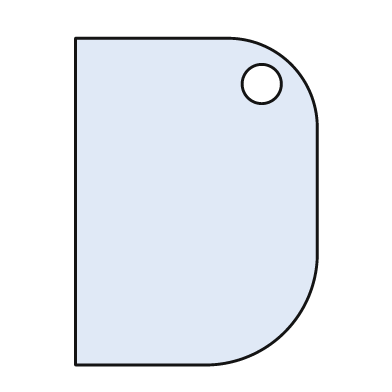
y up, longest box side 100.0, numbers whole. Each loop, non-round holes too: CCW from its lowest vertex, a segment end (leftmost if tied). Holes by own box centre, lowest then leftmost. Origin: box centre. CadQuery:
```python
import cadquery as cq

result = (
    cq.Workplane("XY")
    .moveTo(-37.0, -50.0)
    .lineTo(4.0, -50.0)
    .threePointArc((27.0, -40.0), (37.0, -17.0))
    .lineTo(37.0, 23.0)
    .threePointArc((29.0, 42.0), (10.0, 50.0))
    .lineTo(-37.0, 50.0)
    .close()
    .moveTo(20.0, 36.0)
    .circle(6.0)
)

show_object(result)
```